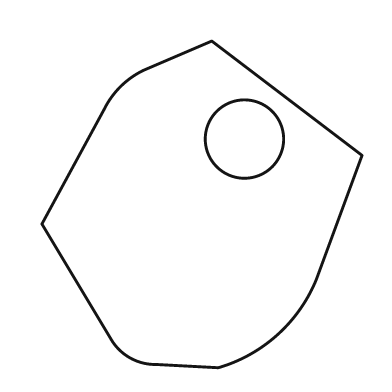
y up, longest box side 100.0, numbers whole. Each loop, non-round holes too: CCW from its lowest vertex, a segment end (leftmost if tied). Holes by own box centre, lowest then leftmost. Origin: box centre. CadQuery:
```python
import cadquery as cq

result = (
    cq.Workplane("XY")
    .moveTo(5.0, -50.0)
    .threePointArc((23.0, -40.0), (35.0, -23.0))
    .lineTo(49.0, 15.0)
    .lineTo(3.0, 50.0)
    .lineTo(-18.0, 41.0)
    .threePointArc((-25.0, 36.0), (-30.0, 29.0))
    .lineTo(-49.0, -6.0)
    .lineTo(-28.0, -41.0)
    .threePointArc((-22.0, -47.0), (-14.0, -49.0))
    .close()
    .moveTo(13.0, 20.0)
    .circle(12.0)
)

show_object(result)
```